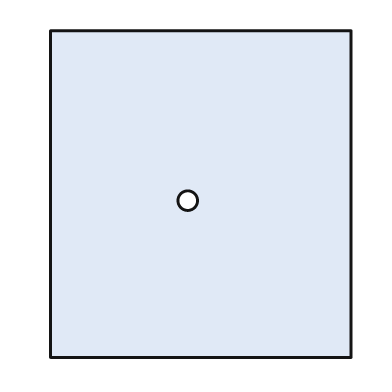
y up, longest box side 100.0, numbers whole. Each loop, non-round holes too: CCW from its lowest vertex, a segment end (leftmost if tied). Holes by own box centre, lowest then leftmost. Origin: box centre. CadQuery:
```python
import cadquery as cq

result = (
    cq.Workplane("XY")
    .moveTo(-46.0, -50.0)
    .lineTo(46.0, -50.0)
    .lineTo(46.0, 50.0)
    .lineTo(-46.0, 50.0)
    .close()
    .moveTo(-4.0, -2.0)
    .circle(3.0)
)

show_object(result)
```